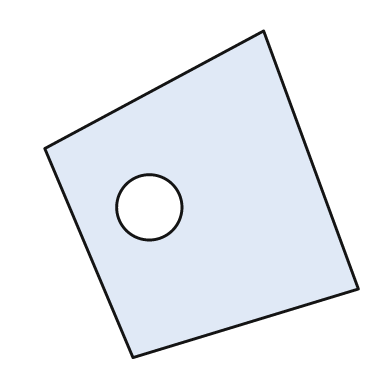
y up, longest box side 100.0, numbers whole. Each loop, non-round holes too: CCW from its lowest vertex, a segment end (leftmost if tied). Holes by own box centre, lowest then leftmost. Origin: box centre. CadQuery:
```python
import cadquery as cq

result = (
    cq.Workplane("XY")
    .moveTo(-21.0, -50.0)
    .lineTo(48.0, -29.0)
    .lineTo(19.0, 50.0)
    .lineTo(-48.0, 14.0)
    .close()
    .moveTo(-16.0, -4.0)
    .circle(10.0)
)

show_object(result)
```